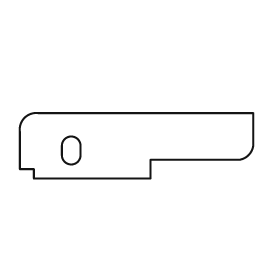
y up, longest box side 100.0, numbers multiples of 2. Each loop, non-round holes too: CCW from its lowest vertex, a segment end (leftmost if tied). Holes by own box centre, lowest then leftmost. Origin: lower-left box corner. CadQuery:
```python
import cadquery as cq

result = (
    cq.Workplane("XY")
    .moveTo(6.0, 0.0)
    .lineTo(56.0, 0.0)
    .lineTo(56.0, 8.0)
    .lineTo(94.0, 8.0)
    .threePointArc((98.0, 10.0), (100.0, 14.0))
    .lineTo(100.0, 28.0)
    .lineTo(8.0, 28.0)
    .threePointArc((2.0, 26.0), (0.0, 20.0))
    .lineTo(0.0, 4.0)
    .lineTo(6.0, 4.0)
    .close()
    .moveTo(18.0, 10.0)
    .threePointArc((22.0, 6.0), (26.0, 10.0))
    .lineTo(26.0, 14.0)
    .threePointArc((22.0, 18.0), (18.0, 14.0))
    .close()
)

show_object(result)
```